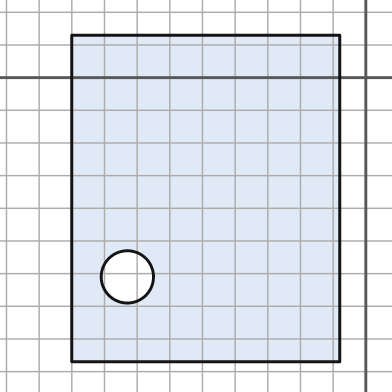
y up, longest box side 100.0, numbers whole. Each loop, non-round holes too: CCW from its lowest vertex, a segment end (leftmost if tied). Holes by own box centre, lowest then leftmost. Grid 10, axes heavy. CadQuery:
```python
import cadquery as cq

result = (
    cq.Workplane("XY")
    .moveTo(-90.0, -87.0)
    .lineTo(-8.0, -87.0)
    .lineTo(-8.0, 13.0)
    .lineTo(-90.0, 13.0)
    .close()
    .moveTo(-73.0, -61.0)
    .circle(8.0)
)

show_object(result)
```